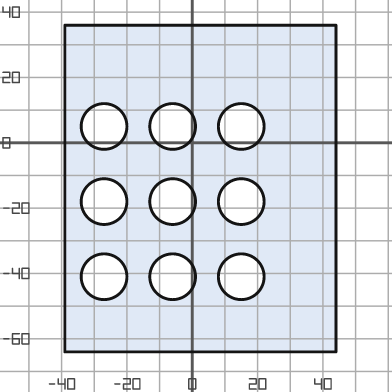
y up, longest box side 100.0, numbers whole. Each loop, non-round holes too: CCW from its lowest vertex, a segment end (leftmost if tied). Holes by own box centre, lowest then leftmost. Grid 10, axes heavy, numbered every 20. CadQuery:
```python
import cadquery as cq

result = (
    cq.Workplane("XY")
    .moveTo(-39.0, -64.0)
    .lineTo(44.0, -64.0)
    .lineTo(44.0, 36.0)
    .lineTo(-39.0, 36.0)
    .close()
    .moveTo(-27.0, -41.0)
    .circle(7.0)
    .moveTo(-6.0, -41.0)
    .circle(7.0)
    .moveTo(15.0, -41.0)
    .circle(7.0)
    .moveTo(-27.0, -18.0)
    .circle(7.0)
    .moveTo(-6.0, -18.0)
    .circle(7.0)
    .moveTo(15.0, -18.0)
    .circle(7.0)
    .moveTo(-27.0, 5.0)
    .circle(7.0)
    .moveTo(-6.0, 5.0)
    .circle(7.0)
    .moveTo(15.0, 5.0)
    .circle(7.0)
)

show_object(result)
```